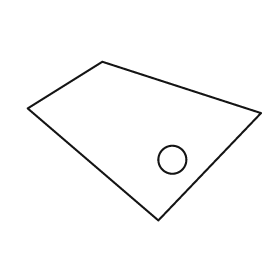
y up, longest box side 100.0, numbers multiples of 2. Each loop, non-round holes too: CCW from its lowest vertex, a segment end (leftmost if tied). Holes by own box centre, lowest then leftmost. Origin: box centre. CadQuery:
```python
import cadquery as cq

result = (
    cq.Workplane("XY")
    .moveTo(6.0, -34.0)
    .lineTo(50.0, 12.0)
    .lineTo(-18.0, 34.0)
    .lineTo(-50.0, 14.0)
    .close()
    .moveTo(12.0, -8.0)
    .circle(6.0)
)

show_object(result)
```